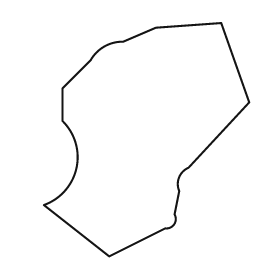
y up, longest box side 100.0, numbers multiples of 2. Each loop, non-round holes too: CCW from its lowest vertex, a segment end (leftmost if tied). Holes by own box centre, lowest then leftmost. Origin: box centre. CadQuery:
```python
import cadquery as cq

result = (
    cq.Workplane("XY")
    .moveTo(-16.0, -50.0)
    .lineTo(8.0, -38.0)
    .threePointArc((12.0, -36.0), (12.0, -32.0))
    .lineTo(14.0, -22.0)
    .threePointArc((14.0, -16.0), (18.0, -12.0))
    .lineTo(44.0, 16.0)
    .lineTo(32.0, 50.0)
    .lineTo(4.0, 48.0)
    .lineTo(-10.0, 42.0)
    .threePointArc((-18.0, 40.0), (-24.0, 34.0))
    .lineTo(-36.0, 22.0)
    .lineTo(-36.0, 8.0)
    .threePointArc((-30.0, -12.0), (-44.0, -28.0))
    .close()
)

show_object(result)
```